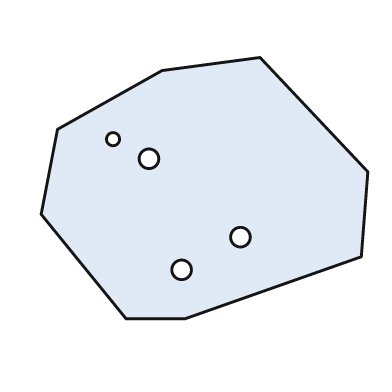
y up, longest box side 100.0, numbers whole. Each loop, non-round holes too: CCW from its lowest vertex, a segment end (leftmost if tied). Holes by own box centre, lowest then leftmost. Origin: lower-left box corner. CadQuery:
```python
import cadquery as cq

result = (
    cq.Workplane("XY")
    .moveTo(26.0, 0.0)
    .lineTo(44.0, 0.0)
    .lineTo(98.0, 19.0)
    .lineTo(100.0, 45.0)
    .lineTo(67.0, 80.0)
    .lineTo(37.0, 76.0)
    .lineTo(5.0, 58.0)
    .lineTo(0.0, 32.0)
    .close()
    .moveTo(43.0, 15.0)
    .circle(3.0)
    .moveTo(61.0, 25.0)
    .circle(3.0)
    .moveTo(33.0, 49.0)
    .circle(3.0)
    .moveTo(22.0, 55.0)
    .circle(2.0)
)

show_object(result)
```